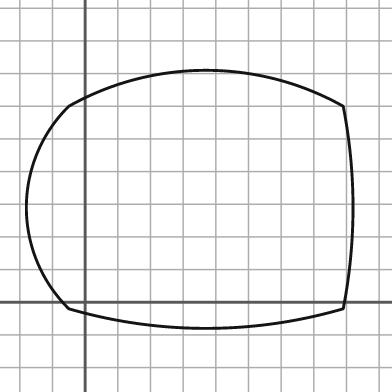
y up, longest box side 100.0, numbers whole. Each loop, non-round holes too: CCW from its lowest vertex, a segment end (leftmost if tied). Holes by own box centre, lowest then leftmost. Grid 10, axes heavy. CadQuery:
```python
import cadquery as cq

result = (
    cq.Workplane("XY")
    .moveTo(-5.0, -2.0)
    .threePointArc((37.0, -8.0), (79.0, -2.0))
    .threePointArc((82.0, 29.0), (79.0, 60.0))
    .threePointArc((37.0, 71.0), (-5.0, 60.0))
    .threePointArc((-18.0, 29.0), (-5.0, -2.0))
    .close()
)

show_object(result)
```